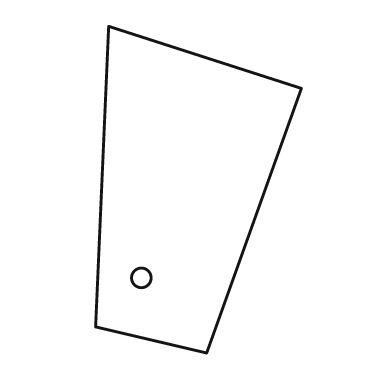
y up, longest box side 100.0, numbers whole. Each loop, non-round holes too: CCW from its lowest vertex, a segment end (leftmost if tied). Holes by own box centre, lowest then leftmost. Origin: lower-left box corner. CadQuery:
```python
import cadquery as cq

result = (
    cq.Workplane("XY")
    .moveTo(34.0, 0.0)
    .lineTo(63.0, 81.0)
    .lineTo(4.0, 100.0)
    .lineTo(0.0, 8.0)
    .close()
    .moveTo(14.0, 23.0)
    .circle(3.0)
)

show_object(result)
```